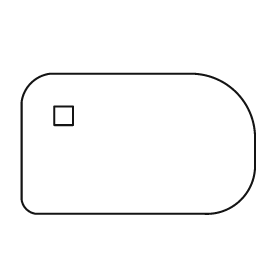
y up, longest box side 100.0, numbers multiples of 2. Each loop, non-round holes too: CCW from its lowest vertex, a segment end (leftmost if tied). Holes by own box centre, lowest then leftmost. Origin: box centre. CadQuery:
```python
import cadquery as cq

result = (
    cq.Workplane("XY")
    .moveTo(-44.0, -30.0)
    .lineTo(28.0, -30.0)
    .threePointArc((44.0, -24.0), (50.0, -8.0))
    .lineTo(50.0, 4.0)
    .threePointArc((42.0, 22.0), (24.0, 30.0))
    .lineTo(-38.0, 30.0)
    .threePointArc((-46.0, 26.0), (-50.0, 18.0))
    .lineTo(-50.0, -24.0)
    .threePointArc((-48.0, -28.0), (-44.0, -30.0))
    .close()
    .moveTo(-36.0, 8.0)
    .lineTo(-28.0, 8.0)
    .lineTo(-28.0, 16.0)
    .lineTo(-36.0, 16.0)
    .close()
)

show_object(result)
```